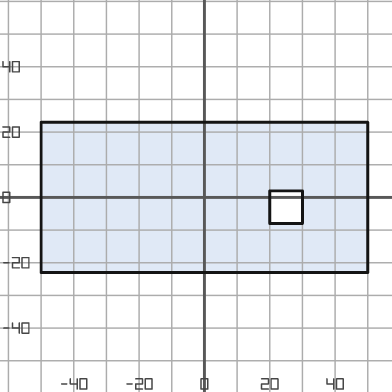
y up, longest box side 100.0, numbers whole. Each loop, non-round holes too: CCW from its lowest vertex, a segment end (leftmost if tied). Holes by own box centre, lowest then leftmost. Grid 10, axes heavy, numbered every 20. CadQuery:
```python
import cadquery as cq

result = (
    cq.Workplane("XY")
    .moveTo(-50.0, -23.0)
    .lineTo(50.0, -23.0)
    .lineTo(50.0, 23.0)
    .lineTo(-50.0, 23.0)
    .close()
    .moveTo(20.0, -8.0)
    .lineTo(30.0, -8.0)
    .lineTo(30.0, 2.0)
    .lineTo(20.0, 2.0)
    .close()
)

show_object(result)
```